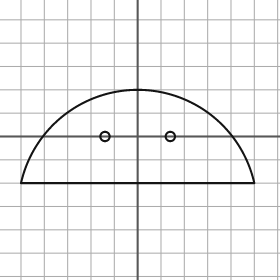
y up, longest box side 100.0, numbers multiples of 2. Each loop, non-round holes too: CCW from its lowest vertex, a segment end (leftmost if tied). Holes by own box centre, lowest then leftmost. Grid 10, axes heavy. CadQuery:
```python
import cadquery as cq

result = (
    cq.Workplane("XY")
    .moveTo(-50.0, -20.0)
    .lineTo(50.0, -20.0)
    .threePointArc((0.0, 20.0), (-50.0, -20.0))
    .close()
    .moveTo(-14.0, 0.0)
    .circle(2.0)
    .moveTo(14.0, 0.0)
    .circle(2.0)
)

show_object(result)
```